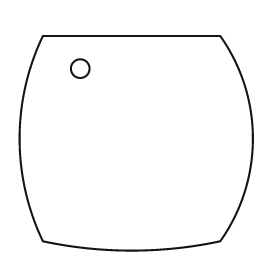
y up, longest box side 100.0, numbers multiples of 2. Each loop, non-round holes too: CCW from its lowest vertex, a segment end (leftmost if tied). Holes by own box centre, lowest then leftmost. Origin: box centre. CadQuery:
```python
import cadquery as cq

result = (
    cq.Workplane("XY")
    .moveTo(-40.0, -42.0)
    .threePointArc((-2.0, -46.0), (36.0, -42.0))
    .threePointArc((50.0, 2.0), (36.0, 46.0))
    .lineTo(-40.0, 46.0)
    .threePointArc((-50.0, 2.0), (-40.0, -42.0))
    .close()
    .moveTo(-24.0, 32.0)
    .circle(4.0)
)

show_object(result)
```